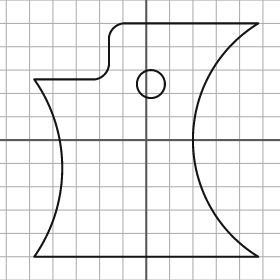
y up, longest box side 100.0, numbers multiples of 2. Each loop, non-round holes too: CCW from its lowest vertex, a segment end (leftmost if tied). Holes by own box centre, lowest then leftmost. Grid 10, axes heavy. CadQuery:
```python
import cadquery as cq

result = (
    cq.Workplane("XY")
    .moveTo(-48.0, -50.0)
    .lineTo(48.0, -50.0)
    .threePointArc((20.0, 0.0), (48.0, 50.0))
    .lineTo(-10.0, 50.0)
    .threePointArc((-14.0, 48.0), (-16.0, 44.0))
    .lineTo(-16.0, 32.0)
    .threePointArc((-18.0, 28.0), (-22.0, 26.0))
    .lineTo(-48.0, 26.0)
    .threePointArc((-36.0, -12.0), (-48.0, -50.0))
    .close()
    .moveTo(2.0, 24.0)
    .circle(6.0)
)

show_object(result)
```